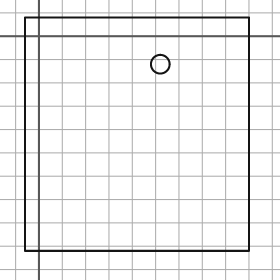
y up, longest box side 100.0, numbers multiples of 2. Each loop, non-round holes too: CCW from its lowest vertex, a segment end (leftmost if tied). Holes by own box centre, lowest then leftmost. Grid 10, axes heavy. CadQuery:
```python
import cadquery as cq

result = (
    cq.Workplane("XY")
    .moveTo(-6.0, -92.0)
    .lineTo(90.0, -92.0)
    .lineTo(90.0, 8.0)
    .lineTo(-6.0, 8.0)
    .close()
    .moveTo(52.0, -12.0)
    .circle(4.0)
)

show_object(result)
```